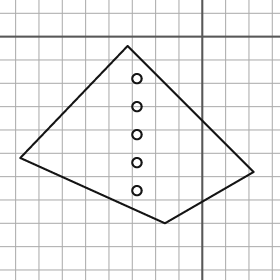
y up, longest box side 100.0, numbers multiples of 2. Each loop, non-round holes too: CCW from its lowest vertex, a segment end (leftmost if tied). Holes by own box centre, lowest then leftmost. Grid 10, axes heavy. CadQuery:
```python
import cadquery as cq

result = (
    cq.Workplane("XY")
    .moveTo(-16.0, -80.0)
    .lineTo(22.0, -58.0)
    .lineTo(-32.0, -4.0)
    .lineTo(-78.0, -52.0)
    .close()
    .moveTo(-28.0, -66.0)
    .circle(2.0)
    .moveTo(-28.0, -54.0)
    .circle(2.0)
    .moveTo(-28.0, -42.0)
    .circle(2.0)
    .moveTo(-28.0, -30.0)
    .circle(2.0)
    .moveTo(-28.0, -18.0)
    .circle(2.0)
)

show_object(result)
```